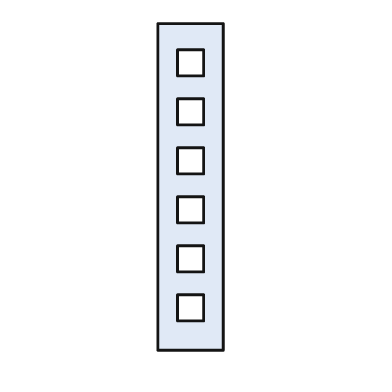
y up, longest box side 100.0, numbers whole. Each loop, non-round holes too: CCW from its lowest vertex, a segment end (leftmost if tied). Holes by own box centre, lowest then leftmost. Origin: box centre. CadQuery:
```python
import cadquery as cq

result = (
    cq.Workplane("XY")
    .moveTo(-10.0, -50.0)
    .lineTo(10.0, -50.0)
    .lineTo(10.0, 50.0)
    .lineTo(-10.0, 50.0)
    .close()
    .moveTo(-4.0, -41.0)
    .lineTo(4.0, -41.0)
    .lineTo(4.0, -33.0)
    .lineTo(-4.0, -33.0)
    .close()
    .moveTo(-4.0, -26.0)
    .lineTo(4.0, -26.0)
    .lineTo(4.0, -18.0)
    .lineTo(-4.0, -18.0)
    .close()
    .moveTo(-4.0, -11.0)
    .lineTo(4.0, -11.0)
    .lineTo(4.0, -3.0)
    .lineTo(-4.0, -3.0)
    .close()
    .moveTo(-4.0, 4.0)
    .lineTo(4.0, 4.0)
    .lineTo(4.0, 12.0)
    .lineTo(-4.0, 12.0)
    .close()
    .moveTo(-4.0, 19.0)
    .lineTo(4.0, 19.0)
    .lineTo(4.0, 27.0)
    .lineTo(-4.0, 27.0)
    .close()
    .moveTo(-4.0, 34.0)
    .lineTo(4.0, 34.0)
    .lineTo(4.0, 42.0)
    .lineTo(-4.0, 42.0)
    .close()
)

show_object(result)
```